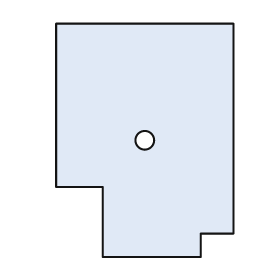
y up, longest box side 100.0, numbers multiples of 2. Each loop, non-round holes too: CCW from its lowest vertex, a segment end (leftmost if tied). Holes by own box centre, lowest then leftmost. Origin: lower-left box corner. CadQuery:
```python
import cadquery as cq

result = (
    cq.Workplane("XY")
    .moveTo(20.0, 0.0)
    .lineTo(62.0, 0.0)
    .lineTo(62.0, 10.0)
    .lineTo(76.0, 10.0)
    .lineTo(76.0, 100.0)
    .lineTo(0.0, 100.0)
    .lineTo(0.0, 30.0)
    .lineTo(20.0, 30.0)
    .close()
    .moveTo(38.0, 50.0)
    .circle(4.0)
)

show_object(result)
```